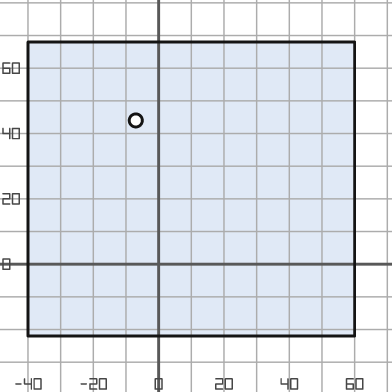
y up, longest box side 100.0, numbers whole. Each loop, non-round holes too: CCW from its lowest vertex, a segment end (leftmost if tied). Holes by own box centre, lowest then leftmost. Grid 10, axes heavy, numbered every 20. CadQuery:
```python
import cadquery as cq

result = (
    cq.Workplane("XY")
    .moveTo(-40.0, -22.0)
    .lineTo(60.0, -22.0)
    .lineTo(60.0, 68.0)
    .lineTo(-40.0, 68.0)
    .close()
    .moveTo(-7.0, 44.0)
    .circle(2.0)
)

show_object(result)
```